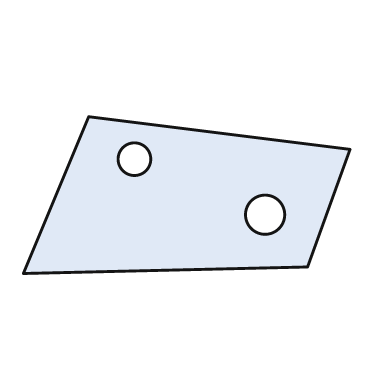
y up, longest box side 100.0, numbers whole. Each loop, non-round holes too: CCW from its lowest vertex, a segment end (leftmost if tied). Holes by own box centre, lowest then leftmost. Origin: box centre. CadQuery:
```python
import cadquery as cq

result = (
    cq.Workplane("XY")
    .moveTo(-50.0, -24.0)
    .lineTo(37.0, -22.0)
    .lineTo(50.0, 14.0)
    .lineTo(-30.0, 24.0)
    .close()
    .moveTo(24.0, -6.0)
    .circle(6.0)
    .moveTo(-16.0, 11.0)
    .circle(5.0)
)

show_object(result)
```